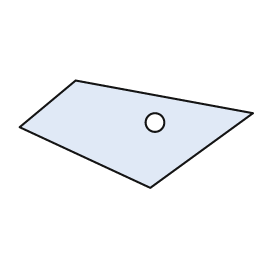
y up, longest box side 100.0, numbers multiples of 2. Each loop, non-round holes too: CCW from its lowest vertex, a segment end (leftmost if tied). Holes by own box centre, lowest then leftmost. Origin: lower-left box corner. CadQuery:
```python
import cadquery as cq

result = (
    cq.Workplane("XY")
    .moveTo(56.0, 0.0)
    .lineTo(100.0, 32.0)
    .lineTo(24.0, 46.0)
    .lineTo(0.0, 26.0)
    .close()
    .moveTo(58.0, 28.0)
    .circle(4.0)
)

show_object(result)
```